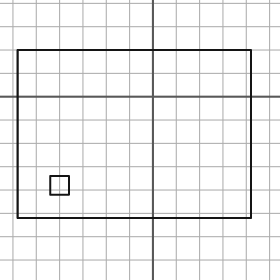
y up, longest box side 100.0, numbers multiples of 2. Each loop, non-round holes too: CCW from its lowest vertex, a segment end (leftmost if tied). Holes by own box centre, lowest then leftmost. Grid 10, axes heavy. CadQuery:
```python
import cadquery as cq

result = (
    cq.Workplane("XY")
    .moveTo(-58.0, -52.0)
    .lineTo(42.0, -52.0)
    .lineTo(42.0, 20.0)
    .lineTo(-58.0, 20.0)
    .close()
    .moveTo(-44.0, -42.0)
    .lineTo(-36.0, -42.0)
    .lineTo(-36.0, -34.0)
    .lineTo(-44.0, -34.0)
    .close()
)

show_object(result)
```